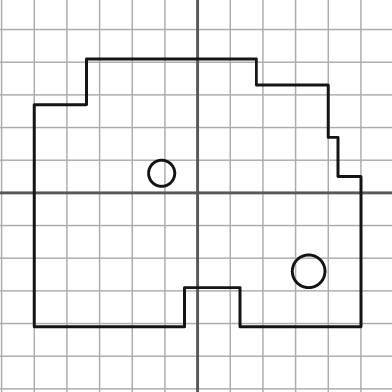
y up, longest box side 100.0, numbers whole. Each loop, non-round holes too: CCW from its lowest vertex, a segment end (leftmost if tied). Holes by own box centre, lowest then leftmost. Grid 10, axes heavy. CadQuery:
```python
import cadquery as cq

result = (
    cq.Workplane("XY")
    .moveTo(-50.0, -41.0)
    .lineTo(-4.0, -41.0)
    .lineTo(-4.0, -29.0)
    .lineTo(13.0, -29.0)
    .lineTo(13.0, -41.0)
    .lineTo(50.0, -41.0)
    .lineTo(50.0, 5.0)
    .lineTo(43.0, 5.0)
    .lineTo(43.0, 17.0)
    .lineTo(40.0, 17.0)
    .lineTo(40.0, 33.0)
    .lineTo(18.0, 33.0)
    .lineTo(18.0, 41.0)
    .lineTo(-34.0, 41.0)
    .lineTo(-34.0, 27.0)
    .lineTo(-50.0, 27.0)
    .close()
    .moveTo(34.0, -24.0)
    .circle(5.0)
    .moveTo(-11.0, 6.0)
    .circle(4.0)
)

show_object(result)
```